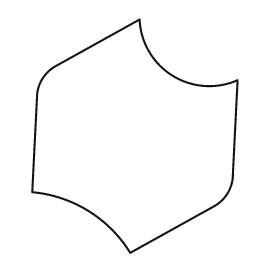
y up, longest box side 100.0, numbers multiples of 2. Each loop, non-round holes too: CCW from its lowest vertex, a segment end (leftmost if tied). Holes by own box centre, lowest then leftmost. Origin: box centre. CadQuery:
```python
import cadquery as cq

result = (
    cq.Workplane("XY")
    .moveTo(-2.0, -50.0)
    .lineTo(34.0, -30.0)
    .threePointArc((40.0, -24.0), (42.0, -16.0))
    .lineTo(44.0, 24.0)
    .threePointArc((16.0, 26.0), (2.0, 50.0))
    .lineTo(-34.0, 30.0)
    .threePointArc((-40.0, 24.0), (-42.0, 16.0))
    .lineTo(-44.0, -24.0)
    .threePointArc((-20.0, -32.0), (-2.0, -50.0))
    .close()
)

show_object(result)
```